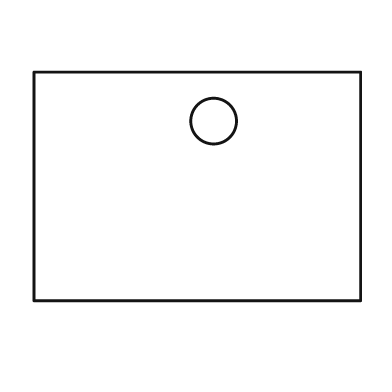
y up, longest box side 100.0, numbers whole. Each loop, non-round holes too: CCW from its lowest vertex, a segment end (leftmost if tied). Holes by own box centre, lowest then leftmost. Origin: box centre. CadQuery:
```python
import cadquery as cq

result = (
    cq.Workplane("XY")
    .moveTo(-50.0, -35.0)
    .lineTo(50.0, -35.0)
    .lineTo(50.0, 35.0)
    .lineTo(-50.0, 35.0)
    .close()
    .moveTo(5.0, 20.0)
    .circle(7.0)
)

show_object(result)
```